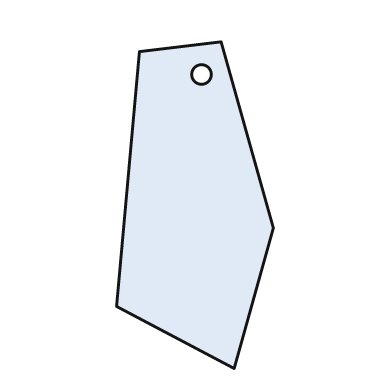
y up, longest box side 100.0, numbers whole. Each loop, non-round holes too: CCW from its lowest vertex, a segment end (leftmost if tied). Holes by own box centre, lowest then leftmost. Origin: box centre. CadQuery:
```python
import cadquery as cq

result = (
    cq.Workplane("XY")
    .moveTo(12.0, -50.0)
    .lineTo(24.0, -7.0)
    .lineTo(8.0, 50.0)
    .lineTo(-17.0, 47.0)
    .lineTo(-24.0, -31.0)
    .close()
    .moveTo(2.0, 40.0)
    .circle(3.0)
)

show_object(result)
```